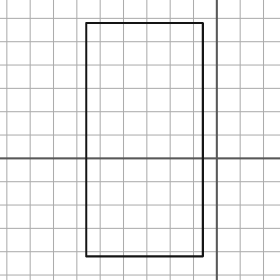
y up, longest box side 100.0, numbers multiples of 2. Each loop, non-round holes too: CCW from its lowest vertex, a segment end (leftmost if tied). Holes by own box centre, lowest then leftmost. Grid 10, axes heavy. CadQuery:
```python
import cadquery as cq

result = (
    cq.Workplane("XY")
    .moveTo(-56.0, -42.0)
    .lineTo(-6.0, -42.0)
    .lineTo(-6.0, 58.0)
    .lineTo(-56.0, 58.0)
    .close()
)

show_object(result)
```